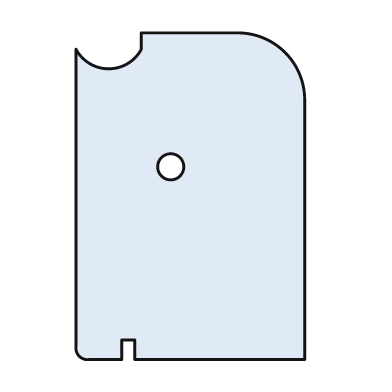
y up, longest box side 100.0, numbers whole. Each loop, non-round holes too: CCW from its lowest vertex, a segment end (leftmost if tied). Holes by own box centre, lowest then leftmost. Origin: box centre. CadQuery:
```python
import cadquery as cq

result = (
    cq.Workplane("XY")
    .moveTo(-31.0, -50.0)
    .lineTo(-21.0, -50.0)
    .lineTo(-21.0, -44.0)
    .lineTo(-17.0, -44.0)
    .lineTo(-17.0, -50.0)
    .lineTo(35.0, -50.0)
    .lineTo(35.0, 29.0)
    .threePointArc((29.0, 44.0), (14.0, 50.0))
    .lineTo(-15.0, 50.0)
    .lineTo(-15.0, 45.0)
    .threePointArc((-25.0, 39.0), (-35.0, 45.0))
    .lineTo(-35.0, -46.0)
    .threePointArc((-34.0, -49.0), (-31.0, -50.0))
    .close()
    .moveTo(-6.0, 9.0)
    .circle(4.0)
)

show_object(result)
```